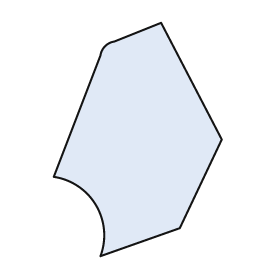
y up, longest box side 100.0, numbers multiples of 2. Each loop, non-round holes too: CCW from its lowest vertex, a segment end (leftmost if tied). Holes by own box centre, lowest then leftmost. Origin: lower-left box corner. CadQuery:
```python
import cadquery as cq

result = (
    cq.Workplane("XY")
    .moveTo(20.0, 0.0)
    .lineTo(54.0, 12.0)
    .lineTo(72.0, 50.0)
    .lineTo(46.0, 100.0)
    .lineTo(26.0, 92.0)
    .threePointArc((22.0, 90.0), (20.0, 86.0))
    .lineTo(0.0, 34.0)
    .threePointArc((18.0, 22.0), (20.0, 0.0))
    .close()
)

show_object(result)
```